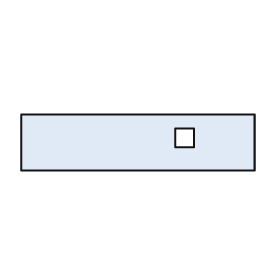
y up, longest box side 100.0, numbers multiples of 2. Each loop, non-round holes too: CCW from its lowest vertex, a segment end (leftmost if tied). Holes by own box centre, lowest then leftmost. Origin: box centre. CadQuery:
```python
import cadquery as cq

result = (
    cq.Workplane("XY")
    .moveTo(-50.0, -12.0)
    .lineTo(50.0, -12.0)
    .lineTo(50.0, 12.0)
    .lineTo(-50.0, 12.0)
    .close()
    .moveTo(16.0, -2.0)
    .lineTo(24.0, -2.0)
    .lineTo(24.0, 6.0)
    .lineTo(16.0, 6.0)
    .close()
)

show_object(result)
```